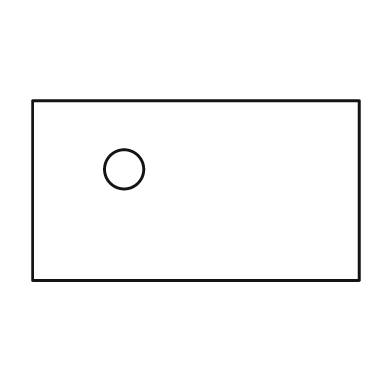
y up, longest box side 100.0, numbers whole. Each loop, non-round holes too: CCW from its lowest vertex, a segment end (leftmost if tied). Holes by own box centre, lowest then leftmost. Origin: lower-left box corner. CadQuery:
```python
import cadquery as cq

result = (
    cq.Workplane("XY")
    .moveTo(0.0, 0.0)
    .lineTo(100.0, 0.0)
    .lineTo(100.0, 55.0)
    .lineTo(0.0, 55.0)
    .close()
    .moveTo(28.0, 34.0)
    .circle(6.0)
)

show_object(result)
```